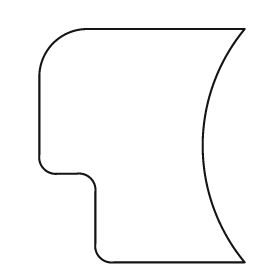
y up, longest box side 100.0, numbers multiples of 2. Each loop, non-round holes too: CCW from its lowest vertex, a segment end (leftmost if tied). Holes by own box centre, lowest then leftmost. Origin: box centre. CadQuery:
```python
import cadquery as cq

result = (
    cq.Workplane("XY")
    .moveTo(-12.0, -50.0)
    .lineTo(44.0, -50.0)
    .threePointArc((26.0, 0.0), (44.0, 50.0))
    .lineTo(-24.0, 50.0)
    .threePointArc((-38.0, 44.0), (-44.0, 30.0))
    .lineTo(-44.0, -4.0)
    .threePointArc((-42.0, -10.0), (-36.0, -12.0))
    .lineTo(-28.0, -12.0)
    .threePointArc((-22.0, -14.0), (-20.0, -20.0))
    .lineTo(-20.0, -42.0)
    .threePointArc((-18.0, -48.0), (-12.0, -50.0))
    .close()
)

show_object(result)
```